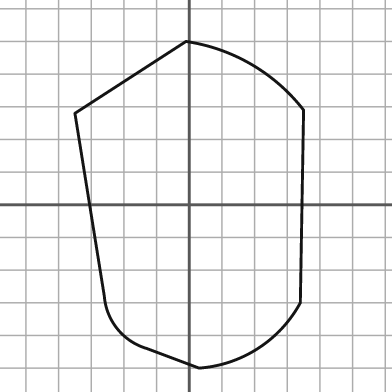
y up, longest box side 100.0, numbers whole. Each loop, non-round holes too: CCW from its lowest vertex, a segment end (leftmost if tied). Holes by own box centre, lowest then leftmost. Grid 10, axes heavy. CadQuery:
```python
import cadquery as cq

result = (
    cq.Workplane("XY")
    .moveTo(3.0, -50.0)
    .threePointArc((21.0, -44.0), (34.0, -30.0))
    .lineTo(35.0, 29.0)
    .threePointArc((19.0, 43.0), (-1.0, 50.0))
    .lineTo(-35.0, 28.0)
    .lineTo(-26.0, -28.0)
    .threePointArc((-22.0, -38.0), (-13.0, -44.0))
    .close()
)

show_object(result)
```